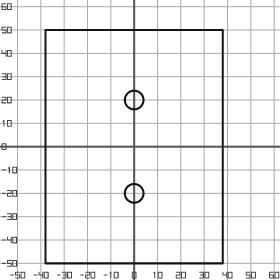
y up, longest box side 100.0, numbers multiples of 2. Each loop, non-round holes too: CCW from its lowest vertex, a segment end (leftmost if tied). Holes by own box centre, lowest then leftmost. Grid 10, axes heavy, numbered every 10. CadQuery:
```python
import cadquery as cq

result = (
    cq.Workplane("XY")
    .moveTo(-38.0, -50.0)
    .lineTo(38.0, -50.0)
    .lineTo(38.0, 50.0)
    .lineTo(-38.0, 50.0)
    .close()
    .moveTo(0.0, -20.0)
    .circle(4.0)
    .moveTo(0.0, 20.0)
    .circle(4.0)
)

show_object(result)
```